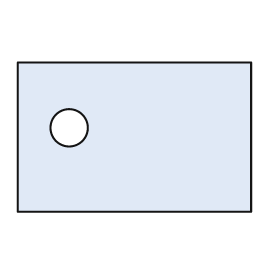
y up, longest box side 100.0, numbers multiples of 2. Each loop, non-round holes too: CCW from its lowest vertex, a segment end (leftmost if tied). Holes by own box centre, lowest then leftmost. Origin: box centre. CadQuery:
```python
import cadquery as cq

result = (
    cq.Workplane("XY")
    .moveTo(-50.0, -32.0)
    .lineTo(50.0, -32.0)
    .lineTo(50.0, 32.0)
    .lineTo(-50.0, 32.0)
    .close()
    .moveTo(-28.0, 4.0)
    .circle(8.0)
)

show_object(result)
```